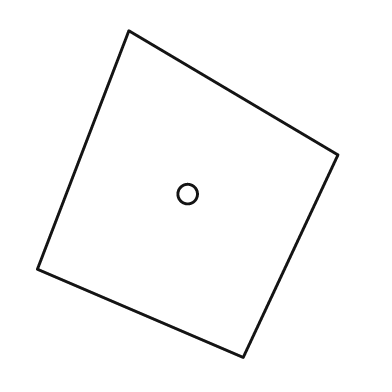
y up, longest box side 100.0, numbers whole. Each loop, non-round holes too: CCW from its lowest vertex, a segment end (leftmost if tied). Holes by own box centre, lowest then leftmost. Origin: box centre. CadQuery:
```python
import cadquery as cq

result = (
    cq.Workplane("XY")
    .moveTo(17.0, -50.0)
    .lineTo(46.0, 12.0)
    .lineTo(-18.0, 50.0)
    .lineTo(-46.0, -23.0)
    .close()
    .moveTo(0.0, 0.0)
    .circle(3.0)
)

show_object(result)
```